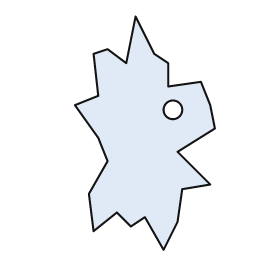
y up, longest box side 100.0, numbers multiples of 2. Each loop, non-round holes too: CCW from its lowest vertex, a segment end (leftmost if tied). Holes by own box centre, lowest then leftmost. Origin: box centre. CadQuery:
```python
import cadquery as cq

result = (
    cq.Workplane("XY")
    .moveTo(8.0, -50.0)
    .lineTo(14.0, -38.0)
    .lineTo(16.0, -24.0)
    .lineTo(28.0, -22.0)
    .lineTo(14.0, -8.0)
    .lineTo(30.0, 2.0)
    .lineTo(28.0, 12.0)
    .lineTo(24.0, 22.0)
    .lineTo(10.0, 20.0)
    .lineTo(10.0, 30.0)
    .lineTo(4.0, 34.0)
    .lineTo(-4.0, 50.0)
    .lineTo(-8.0, 30.0)
    .lineTo(-16.0, 36.0)
    .lineTo(-22.0, 34.0)
    .lineTo(-20.0, 16.0)
    .lineTo(-30.0, 12.0)
    .lineTo(-20.0, -2.0)
    .lineTo(-16.0, -12.0)
    .lineTo(-24.0, -26.0)
    .lineTo(-22.0, -42.0)
    .lineTo(-12.0, -34.0)
    .lineTo(-6.0, -40.0)
    .lineTo(0.0, -36.0)
    .close()
    .moveTo(12.0, 10.0)
    .circle(4.0)
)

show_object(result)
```